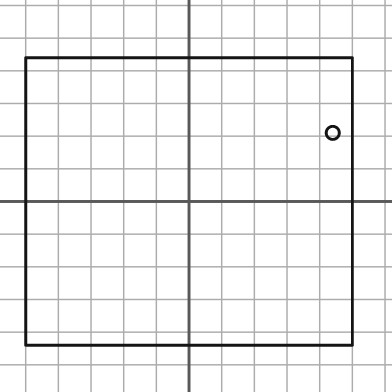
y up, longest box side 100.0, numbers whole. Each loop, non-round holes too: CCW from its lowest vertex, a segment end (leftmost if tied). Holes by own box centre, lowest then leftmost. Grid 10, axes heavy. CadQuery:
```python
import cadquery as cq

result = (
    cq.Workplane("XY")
    .moveTo(-50.0, -44.0)
    .lineTo(50.0, -44.0)
    .lineTo(50.0, 44.0)
    .lineTo(-50.0, 44.0)
    .close()
    .moveTo(44.0, 21.0)
    .circle(2.0)
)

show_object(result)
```